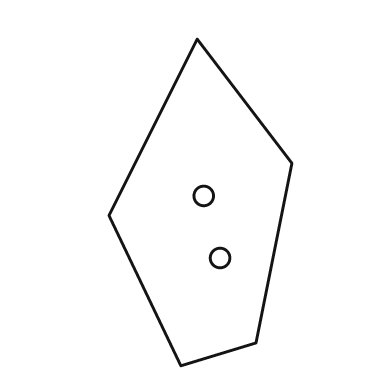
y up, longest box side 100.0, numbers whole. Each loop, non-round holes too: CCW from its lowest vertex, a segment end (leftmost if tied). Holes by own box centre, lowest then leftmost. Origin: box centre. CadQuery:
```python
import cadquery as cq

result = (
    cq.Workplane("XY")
    .moveTo(-6.0, -50.0)
    .lineTo(17.0, -43.0)
    .lineTo(28.0, 12.0)
    .lineTo(-1.0, 50.0)
    .lineTo(-28.0, -4.0)
    .close()
    .moveTo(6.0, -17.0)
    .circle(3.0)
    .moveTo(1.0, 2.0)
    .circle(3.0)
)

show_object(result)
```